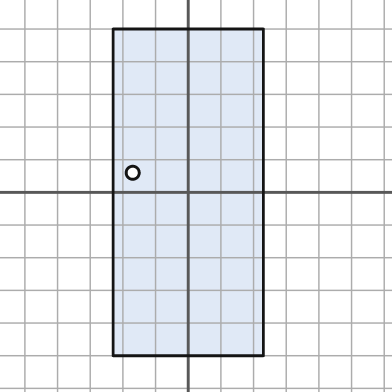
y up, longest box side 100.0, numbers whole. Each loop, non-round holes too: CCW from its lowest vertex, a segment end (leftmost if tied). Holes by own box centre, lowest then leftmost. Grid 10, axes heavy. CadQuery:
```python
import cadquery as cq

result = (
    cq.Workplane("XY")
    .moveTo(-23.0, -50.0)
    .lineTo(23.0, -50.0)
    .lineTo(23.0, 50.0)
    .lineTo(-23.0, 50.0)
    .close()
    .moveTo(-17.0, 6.0)
    .circle(2.0)
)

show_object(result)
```